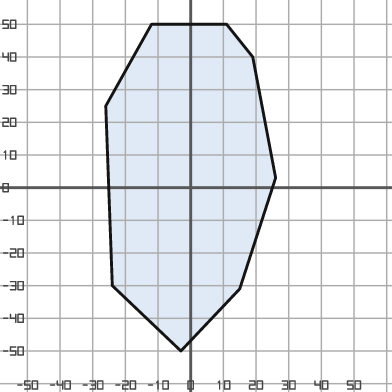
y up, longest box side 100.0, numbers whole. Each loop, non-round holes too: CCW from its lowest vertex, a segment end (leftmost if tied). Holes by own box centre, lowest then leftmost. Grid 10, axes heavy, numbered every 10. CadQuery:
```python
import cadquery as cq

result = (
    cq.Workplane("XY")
    .moveTo(-3.0, -50.0)
    .lineTo(15.0, -31.0)
    .lineTo(26.0, 3.0)
    .lineTo(19.0, 40.0)
    .lineTo(11.0, 50.0)
    .lineTo(-12.0, 50.0)
    .lineTo(-26.0, 25.0)
    .lineTo(-24.0, -30.0)
    .close()
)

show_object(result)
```